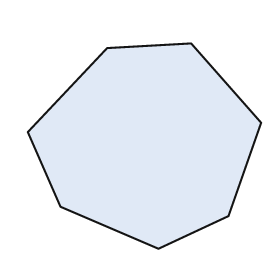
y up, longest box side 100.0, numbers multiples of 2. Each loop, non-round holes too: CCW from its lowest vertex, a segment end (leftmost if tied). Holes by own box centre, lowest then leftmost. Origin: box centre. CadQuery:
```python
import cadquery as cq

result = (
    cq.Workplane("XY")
    .moveTo(6.0, -44.0)
    .lineTo(36.0, -30.0)
    .lineTo(50.0, 10.0)
    .lineTo(20.0, 44.0)
    .lineTo(-16.0, 42.0)
    .lineTo(-50.0, 6.0)
    .lineTo(-36.0, -26.0)
    .close()
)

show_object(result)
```